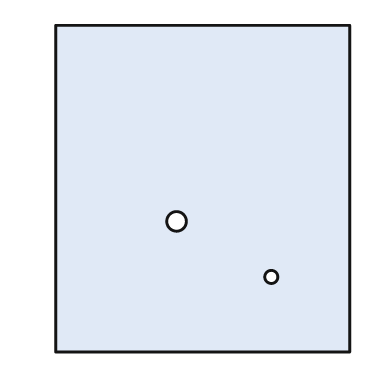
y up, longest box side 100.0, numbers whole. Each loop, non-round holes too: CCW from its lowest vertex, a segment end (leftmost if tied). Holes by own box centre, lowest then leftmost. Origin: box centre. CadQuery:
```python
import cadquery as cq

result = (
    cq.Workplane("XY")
    .moveTo(-45.0, -50.0)
    .lineTo(45.0, -50.0)
    .lineTo(45.0, 50.0)
    .lineTo(-45.0, 50.0)
    .close()
    .moveTo(21.0, -27.0)
    .circle(2.0)
    .moveTo(-8.0, -10.0)
    .circle(3.0)
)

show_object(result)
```